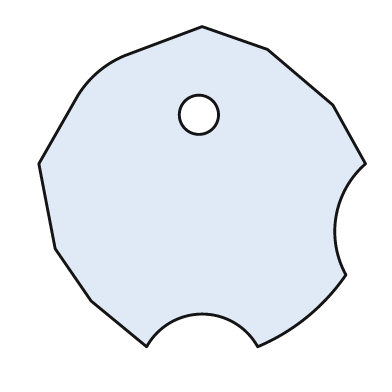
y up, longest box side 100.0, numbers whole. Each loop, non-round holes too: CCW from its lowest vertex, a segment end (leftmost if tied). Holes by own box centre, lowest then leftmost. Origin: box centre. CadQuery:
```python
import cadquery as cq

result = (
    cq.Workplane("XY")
    .moveTo(-17.0, -49.0)
    .threePointArc((0.0, -39.0), (17.0, -49.0))
    .threePointArc((32.0, -40.0), (44.0, -27.0))
    .threePointArc((41.0, -9.0), (50.0, 7.0))
    .lineTo(40.0, 25.0)
    .lineTo(20.0, 42.0)
    .lineTo(0.0, 49.0)
    .lineTo(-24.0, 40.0)
    .threePointArc((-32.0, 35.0), (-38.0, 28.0))
    .lineTo(-50.0, 7.0)
    .lineTo(-45.0, -19.0)
    .lineTo(-34.0, -35.0)
    .close()
    .moveTo(-1.0, 22.0)
    .circle(6.0)
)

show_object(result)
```